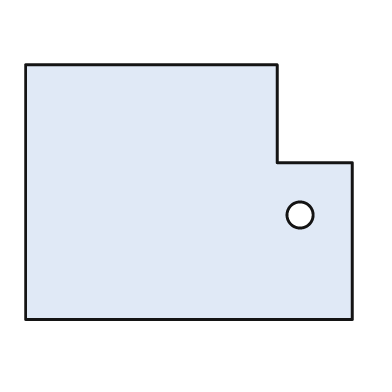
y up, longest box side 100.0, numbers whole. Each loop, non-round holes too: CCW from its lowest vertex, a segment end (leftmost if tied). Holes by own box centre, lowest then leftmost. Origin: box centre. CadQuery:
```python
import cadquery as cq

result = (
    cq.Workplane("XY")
    .moveTo(-50.0, -39.0)
    .lineTo(50.0, -39.0)
    .lineTo(50.0, 9.0)
    .lineTo(27.0, 9.0)
    .lineTo(27.0, 39.0)
    .lineTo(-50.0, 39.0)
    .close()
    .moveTo(34.0, -7.0)
    .circle(4.0)
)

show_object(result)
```